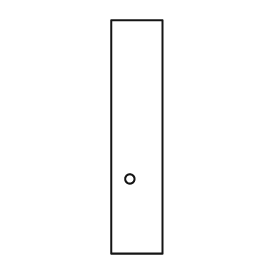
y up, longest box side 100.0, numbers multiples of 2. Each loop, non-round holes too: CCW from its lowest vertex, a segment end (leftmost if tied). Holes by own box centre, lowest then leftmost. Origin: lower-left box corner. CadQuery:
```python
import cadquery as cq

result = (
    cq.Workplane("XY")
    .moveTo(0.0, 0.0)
    .lineTo(22.0, 0.0)
    .lineTo(22.0, 100.0)
    .lineTo(0.0, 100.0)
    .close()
    .moveTo(8.0, 32.0)
    .circle(2.0)
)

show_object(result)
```